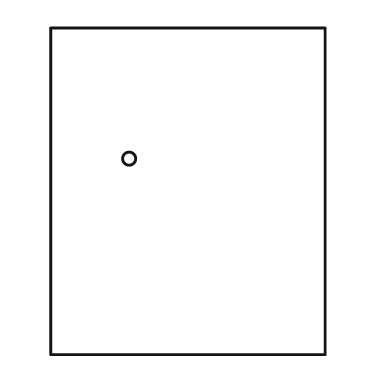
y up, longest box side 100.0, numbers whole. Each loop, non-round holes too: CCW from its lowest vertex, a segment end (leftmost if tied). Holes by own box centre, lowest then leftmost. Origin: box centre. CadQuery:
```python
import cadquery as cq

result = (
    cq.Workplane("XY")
    .moveTo(-42.0, -50.0)
    .lineTo(42.0, -50.0)
    .lineTo(42.0, 50.0)
    .lineTo(-42.0, 50.0)
    .close()
    .moveTo(-18.0, 10.0)
    .circle(2.0)
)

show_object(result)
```